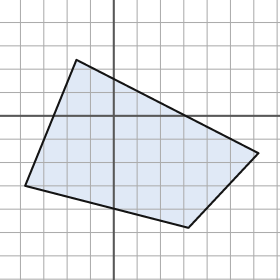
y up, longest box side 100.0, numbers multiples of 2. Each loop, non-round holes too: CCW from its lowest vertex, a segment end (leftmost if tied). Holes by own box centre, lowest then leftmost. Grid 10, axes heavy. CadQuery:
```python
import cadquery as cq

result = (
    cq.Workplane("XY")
    .moveTo(32.0, -48.0)
    .lineTo(62.0, -16.0)
    .lineTo(-16.0, 24.0)
    .lineTo(-38.0, -30.0)
    .close()
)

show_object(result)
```